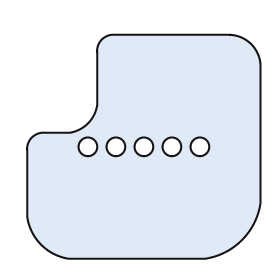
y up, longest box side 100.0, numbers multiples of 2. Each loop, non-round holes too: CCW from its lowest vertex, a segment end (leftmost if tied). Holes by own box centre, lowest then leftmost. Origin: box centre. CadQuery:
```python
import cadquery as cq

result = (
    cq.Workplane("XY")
    .moveTo(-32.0, -48.0)
    .lineTo(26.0, -48.0)
    .threePointArc((42.0, -40.0), (50.0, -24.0))
    .lineTo(50.0, 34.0)
    .threePointArc((46.0, 44.0), (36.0, 48.0))
    .lineTo(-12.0, 48.0)
    .threePointArc((-18.0, 46.0), (-20.0, 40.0))
    .lineTo(-20.0, 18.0)
    .threePointArc((-24.0, 10.0), (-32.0, 6.0))
    .lineTo(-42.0, 6.0)
    .threePointArc((-48.0, 4.0), (-50.0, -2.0))
    .lineTo(-50.0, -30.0)
    .threePointArc((-44.0, -42.0), (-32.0, -48.0))
    .close()
    .moveTo(-24.0, 0.0)
    .circle(4.0)
    .moveTo(-12.0, 0.0)
    .circle(4.0)
    .moveTo(0.0, 0.0)
    .circle(4.0)
    .moveTo(12.0, 0.0)
    .circle(4.0)
    .moveTo(24.0, 0.0)
    .circle(4.0)
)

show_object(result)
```